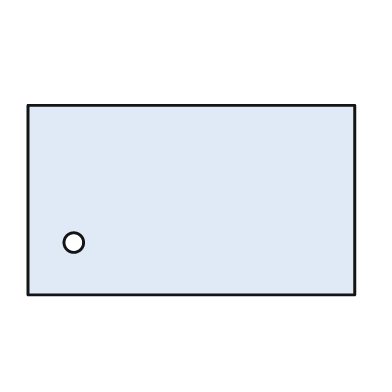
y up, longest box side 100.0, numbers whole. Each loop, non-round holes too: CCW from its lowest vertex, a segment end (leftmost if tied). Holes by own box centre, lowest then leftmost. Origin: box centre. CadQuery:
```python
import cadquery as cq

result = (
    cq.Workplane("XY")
    .moveTo(-50.0, -29.0)
    .lineTo(50.0, -29.0)
    .lineTo(50.0, 29.0)
    .lineTo(-50.0, 29.0)
    .close()
    .moveTo(-36.0, -13.0)
    .circle(3.0)
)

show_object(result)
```